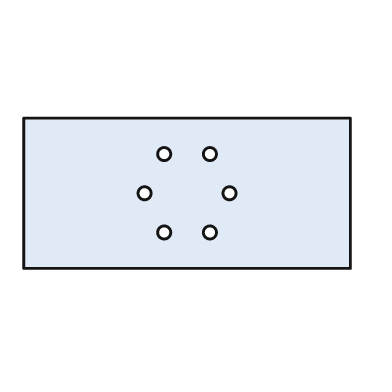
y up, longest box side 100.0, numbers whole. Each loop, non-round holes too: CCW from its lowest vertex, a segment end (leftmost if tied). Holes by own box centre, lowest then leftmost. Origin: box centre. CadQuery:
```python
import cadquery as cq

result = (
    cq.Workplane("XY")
    .moveTo(-50.0, -23.0)
    .lineTo(50.0, -23.0)
    .lineTo(50.0, 23.0)
    .lineTo(-50.0, 23.0)
    .close()
    .moveTo(-7.0, -12.0)
    .circle(2.0)
    .moveTo(7.0, -12.0)
    .circle(2.0)
    .moveTo(-13.0, 0.0)
    .circle(2.0)
    .moveTo(13.0, 0.0)
    .circle(2.0)
    .moveTo(-7.0, 12.0)
    .circle(2.0)
    .moveTo(7.0, 12.0)
    .circle(2.0)
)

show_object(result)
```